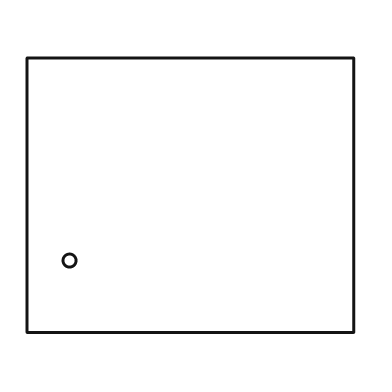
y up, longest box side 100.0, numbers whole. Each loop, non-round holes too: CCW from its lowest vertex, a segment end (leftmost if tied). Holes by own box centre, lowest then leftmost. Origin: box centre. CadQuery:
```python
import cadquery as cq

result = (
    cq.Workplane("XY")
    .moveTo(-50.0, -42.0)
    .lineTo(50.0, -42.0)
    .lineTo(50.0, 42.0)
    .lineTo(-50.0, 42.0)
    .close()
    .moveTo(-37.0, -20.0)
    .circle(2.0)
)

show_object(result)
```